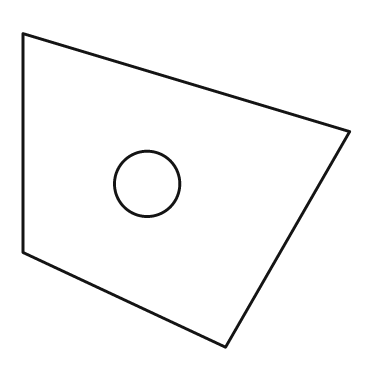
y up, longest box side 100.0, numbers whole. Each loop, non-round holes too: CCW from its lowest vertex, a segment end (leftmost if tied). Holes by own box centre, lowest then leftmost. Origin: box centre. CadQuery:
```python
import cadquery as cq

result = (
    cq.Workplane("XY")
    .moveTo(12.0, -48.0)
    .lineTo(50.0, 18.0)
    .lineTo(-50.0, 48.0)
    .lineTo(-50.0, -19.0)
    .close()
    .moveTo(-12.0, 2.0)
    .circle(10.0)
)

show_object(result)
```